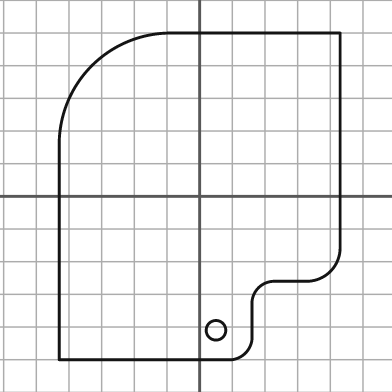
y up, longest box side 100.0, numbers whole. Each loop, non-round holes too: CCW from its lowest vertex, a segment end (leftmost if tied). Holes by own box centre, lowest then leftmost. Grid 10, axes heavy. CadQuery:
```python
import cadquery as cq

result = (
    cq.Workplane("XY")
    .moveTo(-43.0, -50.0)
    .lineTo(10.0, -50.0)
    .threePointArc((14.0, -48.0), (16.0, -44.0))
    .lineTo(16.0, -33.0)
    .threePointArc((18.0, -28.0), (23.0, -26.0))
    .lineTo(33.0, -26.0)
    .threePointArc((40.0, -23.0), (43.0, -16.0))
    .lineTo(43.0, 50.0)
    .lineTo(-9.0, 50.0)
    .threePointArc((-33.0, 40.0), (-43.0, 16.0))
    .close()
    .moveTo(5.0, -41.0)
    .circle(3.0)
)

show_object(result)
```